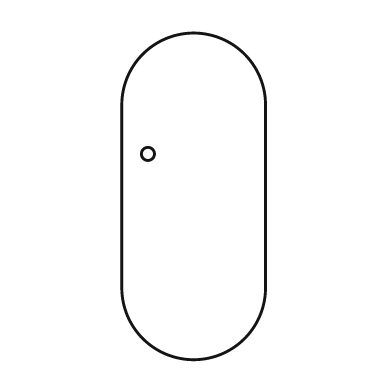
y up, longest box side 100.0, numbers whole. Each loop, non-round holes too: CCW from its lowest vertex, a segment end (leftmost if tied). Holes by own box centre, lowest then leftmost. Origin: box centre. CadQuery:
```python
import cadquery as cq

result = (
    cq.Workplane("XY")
    .moveTo(-22.0, -28.0)
    .threePointArc((0.0, -50.0), (22.0, -28.0))
    .lineTo(22.0, 28.0)
    .threePointArc((0.0, 50.0), (-22.0, 28.0))
    .close()
    .moveTo(-14.0, 13.0)
    .circle(2.0)
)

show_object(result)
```